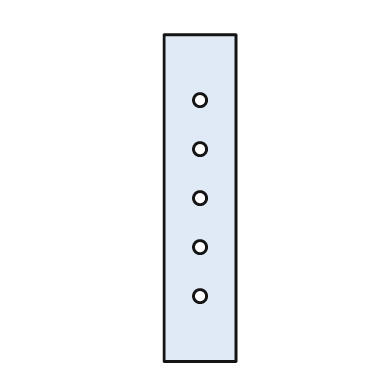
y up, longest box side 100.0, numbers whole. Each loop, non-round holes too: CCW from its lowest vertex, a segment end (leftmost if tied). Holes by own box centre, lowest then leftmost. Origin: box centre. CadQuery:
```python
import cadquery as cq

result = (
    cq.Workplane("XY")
    .moveTo(-11.0, -50.0)
    .lineTo(11.0, -50.0)
    .lineTo(11.0, 50.0)
    .lineTo(-11.0, 50.0)
    .close()
    .moveTo(0.0, -30.0)
    .circle(2.0)
    .moveTo(0.0, -15.0)
    .circle(2.0)
    .moveTo(0.0, 0.0)
    .circle(2.0)
    .moveTo(0.0, 15.0)
    .circle(2.0)
    .moveTo(0.0, 30.0)
    .circle(2.0)
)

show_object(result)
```